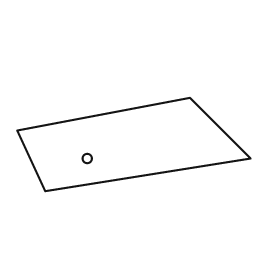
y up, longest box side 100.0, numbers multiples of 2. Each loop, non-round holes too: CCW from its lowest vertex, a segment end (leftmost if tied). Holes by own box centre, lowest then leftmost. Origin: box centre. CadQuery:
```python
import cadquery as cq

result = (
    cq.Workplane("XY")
    .moveTo(-38.0, -20.0)
    .lineTo(50.0, -6.0)
    .lineTo(24.0, 20.0)
    .lineTo(-50.0, 6.0)
    .close()
    .moveTo(-20.0, -6.0)
    .circle(2.0)
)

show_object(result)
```